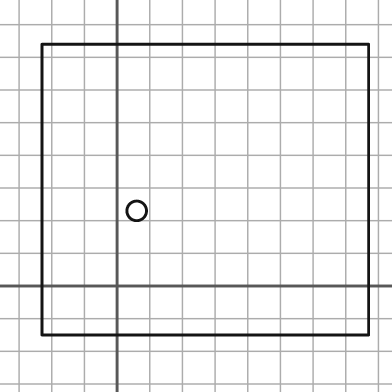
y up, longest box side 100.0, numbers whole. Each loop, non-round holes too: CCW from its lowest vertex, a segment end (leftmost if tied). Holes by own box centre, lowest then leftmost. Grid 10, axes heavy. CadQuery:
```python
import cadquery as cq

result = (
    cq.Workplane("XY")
    .moveTo(-23.0, -15.0)
    .lineTo(77.0, -15.0)
    .lineTo(77.0, 74.0)
    .lineTo(-23.0, 74.0)
    .close()
    .moveTo(6.0, 23.0)
    .circle(3.0)
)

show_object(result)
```